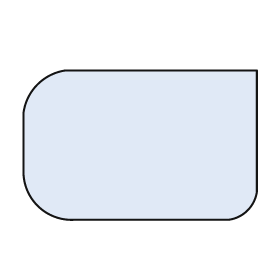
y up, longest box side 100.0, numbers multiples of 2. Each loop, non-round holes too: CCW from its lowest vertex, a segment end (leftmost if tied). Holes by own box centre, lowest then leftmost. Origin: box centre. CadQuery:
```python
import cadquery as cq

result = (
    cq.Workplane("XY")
    .moveTo(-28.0, -32.0)
    .lineTo(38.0, -32.0)
    .threePointArc((46.0, -28.0), (50.0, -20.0))
    .lineTo(50.0, 32.0)
    .lineTo(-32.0, 32.0)
    .threePointArc((-44.0, 26.0), (-50.0, 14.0))
    .lineTo(-50.0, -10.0)
    .threePointArc((-44.0, -26.0), (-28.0, -32.0))
    .close()
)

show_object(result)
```